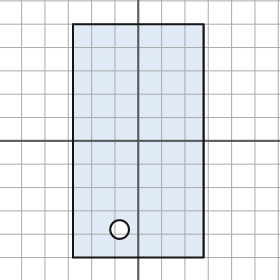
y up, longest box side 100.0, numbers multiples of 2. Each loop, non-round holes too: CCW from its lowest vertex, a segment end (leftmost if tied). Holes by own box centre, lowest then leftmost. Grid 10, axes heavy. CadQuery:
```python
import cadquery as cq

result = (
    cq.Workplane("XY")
    .moveTo(-28.0, -50.0)
    .lineTo(28.0, -50.0)
    .lineTo(28.0, 50.0)
    .lineTo(-28.0, 50.0)
    .close()
    .moveTo(-8.0, -38.0)
    .circle(4.0)
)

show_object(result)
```